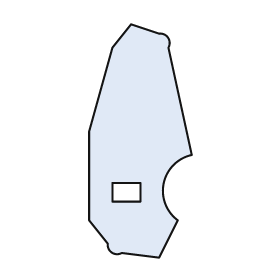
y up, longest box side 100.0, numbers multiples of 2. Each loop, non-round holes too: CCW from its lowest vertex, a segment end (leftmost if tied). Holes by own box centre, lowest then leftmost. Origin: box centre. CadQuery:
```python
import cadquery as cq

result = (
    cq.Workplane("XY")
    .moveTo(8.0, -50.0)
    .lineTo(16.0, -34.0)
    .threePointArc((10.0, -18.0), (22.0, -6.0))
    .lineTo(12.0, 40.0)
    .threePointArc((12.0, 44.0), (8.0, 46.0))
    .lineTo(-4.0, 50.0)
    .lineTo(-12.0, 40.0)
    .lineTo(-22.0, 4.0)
    .lineTo(-22.0, -34.0)
    .lineTo(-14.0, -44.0)
    .threePointArc((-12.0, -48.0), (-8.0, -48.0))
    .close()
    .moveTo(-12.0, -26.0)
    .lineTo(0.0, -26.0)
    .lineTo(0.0, -18.0)
    .lineTo(-12.0, -18.0)
    .close()
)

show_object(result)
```